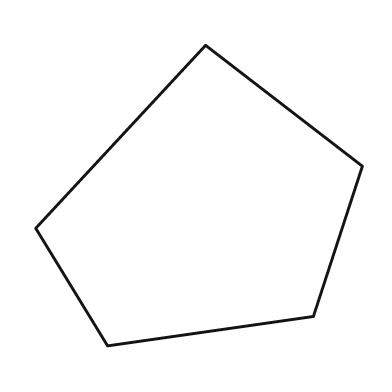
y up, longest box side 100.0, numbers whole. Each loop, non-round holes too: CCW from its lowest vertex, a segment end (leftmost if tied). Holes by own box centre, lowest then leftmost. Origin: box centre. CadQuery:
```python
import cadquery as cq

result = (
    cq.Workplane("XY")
    .moveTo(-28.0, -46.0)
    .lineTo(35.0, -37.0)
    .lineTo(50.0, 9.0)
    .lineTo(2.0, 46.0)
    .lineTo(-50.0, -10.0)
    .close()
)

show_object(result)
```